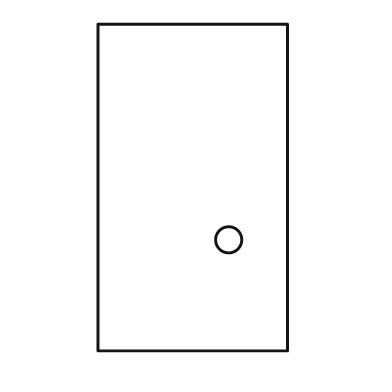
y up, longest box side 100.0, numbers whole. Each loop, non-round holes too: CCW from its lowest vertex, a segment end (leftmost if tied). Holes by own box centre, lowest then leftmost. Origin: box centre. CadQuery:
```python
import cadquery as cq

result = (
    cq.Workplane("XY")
    .moveTo(-29.0, -50.0)
    .lineTo(29.0, -50.0)
    .lineTo(29.0, 50.0)
    .lineTo(-29.0, 50.0)
    .close()
    .moveTo(11.0, -16.0)
    .circle(4.0)
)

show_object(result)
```